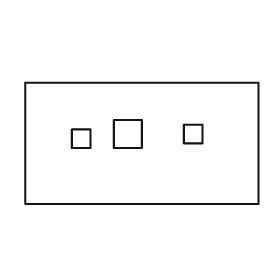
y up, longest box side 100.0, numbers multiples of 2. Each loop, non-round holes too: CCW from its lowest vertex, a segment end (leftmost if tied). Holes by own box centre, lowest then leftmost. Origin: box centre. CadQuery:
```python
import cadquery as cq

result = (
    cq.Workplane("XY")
    .moveTo(-50.0, -26.0)
    .lineTo(50.0, -26.0)
    .lineTo(50.0, 26.0)
    .lineTo(-50.0, 26.0)
    .close()
    .moveTo(-30.0, -2.0)
    .lineTo(-22.0, -2.0)
    .lineTo(-22.0, 6.0)
    .lineTo(-30.0, 6.0)
    .close()
    .moveTo(-12.0, -2.0)
    .lineTo(0.0, -2.0)
    .lineTo(0.0, 10.0)
    .lineTo(-12.0, 10.0)
    .close()
    .moveTo(18.0, 0.0)
    .lineTo(26.0, 0.0)
    .lineTo(26.0, 8.0)
    .lineTo(18.0, 8.0)
    .close()
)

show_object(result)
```